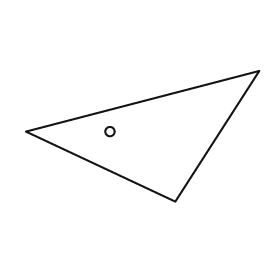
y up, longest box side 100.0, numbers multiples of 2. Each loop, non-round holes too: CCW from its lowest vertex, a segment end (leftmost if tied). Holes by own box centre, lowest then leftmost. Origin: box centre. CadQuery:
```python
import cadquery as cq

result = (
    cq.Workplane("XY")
    .moveTo(14.0, -28.0)
    .lineTo(50.0, 28.0)
    .lineTo(-50.0, 2.0)
    .close()
    .moveTo(-14.0, 2.0)
    .circle(2.0)
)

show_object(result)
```